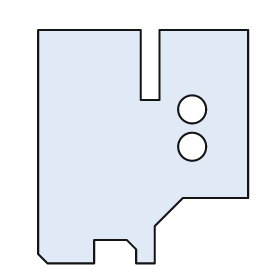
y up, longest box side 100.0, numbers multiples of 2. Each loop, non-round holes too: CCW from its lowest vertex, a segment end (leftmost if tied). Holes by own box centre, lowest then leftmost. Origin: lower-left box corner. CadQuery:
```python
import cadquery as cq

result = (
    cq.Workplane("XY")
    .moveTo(4.0, 0.0)
    .lineTo(24.0, 0.0)
    .lineTo(24.0, 10.0)
    .lineTo(38.0, 10.0)
    .lineTo(42.0, 6.0)
    .lineTo(42.0, 0.0)
    .lineTo(50.0, 0.0)
    .lineTo(50.0, 16.0)
    .lineTo(62.0, 28.0)
    .lineTo(90.0, 28.0)
    .lineTo(90.0, 100.0)
    .lineTo(52.0, 100.0)
    .lineTo(52.0, 70.0)
    .lineTo(44.0, 70.0)
    .lineTo(44.0, 100.0)
    .lineTo(0.0, 100.0)
    .lineTo(0.0, 4.0)
    .close()
    .moveTo(66.0, 50.0)
    .circle(6.0)
    .moveTo(66.0, 66.0)
    .circle(6.0)
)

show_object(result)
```